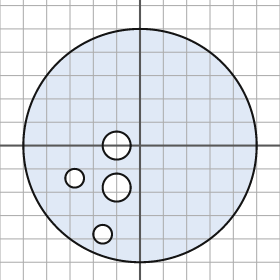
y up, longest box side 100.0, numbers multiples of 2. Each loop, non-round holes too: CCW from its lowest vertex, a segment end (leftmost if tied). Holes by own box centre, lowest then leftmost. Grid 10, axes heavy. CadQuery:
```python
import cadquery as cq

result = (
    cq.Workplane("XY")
    .moveTo(0.0, 0.0)
    .circle(50.0)
    .moveTo(-16.0, -38.0)
    .circle(4.0)
    .moveTo(-10.0, -18.0)
    .circle(6.0)
    .moveTo(-28.0, -14.0)
    .circle(4.0)
    .moveTo(-10.0, 0.0)
    .circle(6.0)
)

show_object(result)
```